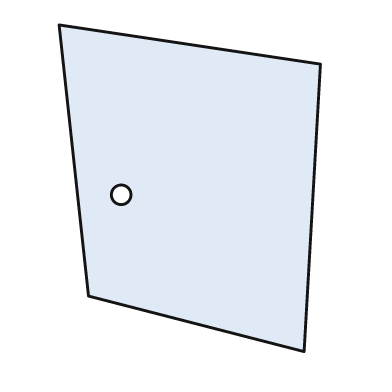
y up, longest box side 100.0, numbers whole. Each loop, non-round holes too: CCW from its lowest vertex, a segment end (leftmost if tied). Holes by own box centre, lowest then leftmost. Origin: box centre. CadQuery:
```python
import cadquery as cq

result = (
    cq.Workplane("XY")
    .moveTo(35.0, -50.0)
    .lineTo(40.0, 38.0)
    .lineTo(-40.0, 50.0)
    .lineTo(-31.0, -33.0)
    .close()
    .moveTo(-21.0, -2.0)
    .circle(3.0)
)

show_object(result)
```